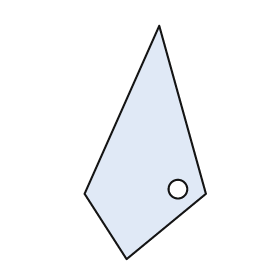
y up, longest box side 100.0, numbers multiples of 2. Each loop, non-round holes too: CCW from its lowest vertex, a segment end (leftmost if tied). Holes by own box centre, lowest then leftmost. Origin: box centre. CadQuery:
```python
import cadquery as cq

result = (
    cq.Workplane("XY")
    .moveTo(-8.0, -50.0)
    .lineTo(26.0, -22.0)
    .lineTo(6.0, 50.0)
    .lineTo(-26.0, -22.0)
    .close()
    .moveTo(14.0, -20.0)
    .circle(4.0)
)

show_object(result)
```